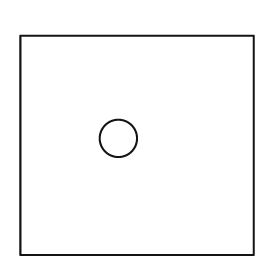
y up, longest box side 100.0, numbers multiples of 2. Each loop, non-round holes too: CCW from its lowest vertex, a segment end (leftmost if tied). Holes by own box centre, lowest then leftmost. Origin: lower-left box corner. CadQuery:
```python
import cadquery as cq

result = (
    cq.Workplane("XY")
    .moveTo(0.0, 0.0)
    .lineTo(100.0, 0.0)
    .lineTo(100.0, 94.0)
    .lineTo(0.0, 94.0)
    .close()
    .moveTo(42.0, 50.0)
    .circle(8.0)
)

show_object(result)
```